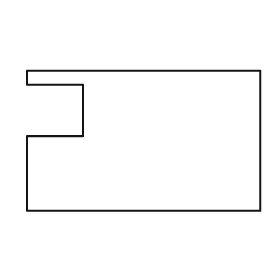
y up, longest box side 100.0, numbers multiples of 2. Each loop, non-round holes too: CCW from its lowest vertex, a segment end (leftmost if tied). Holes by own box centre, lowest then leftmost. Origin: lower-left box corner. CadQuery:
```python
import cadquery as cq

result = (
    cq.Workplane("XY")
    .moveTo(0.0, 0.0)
    .lineTo(100.0, 0.0)
    .lineTo(100.0, 60.0)
    .lineTo(0.0, 60.0)
    .lineTo(0.0, 54.0)
    .lineTo(24.0, 54.0)
    .lineTo(24.0, 32.0)
    .lineTo(0.0, 32.0)
    .close()
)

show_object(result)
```